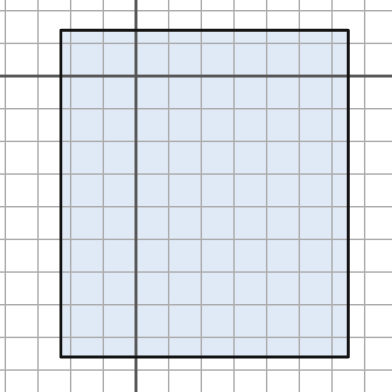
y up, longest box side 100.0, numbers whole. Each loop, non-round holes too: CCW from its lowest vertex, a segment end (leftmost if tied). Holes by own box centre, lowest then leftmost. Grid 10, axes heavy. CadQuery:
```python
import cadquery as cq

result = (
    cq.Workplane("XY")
    .moveTo(-23.0, -86.0)
    .lineTo(65.0, -86.0)
    .lineTo(65.0, 14.0)
    .lineTo(-23.0, 14.0)
    .close()
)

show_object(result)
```